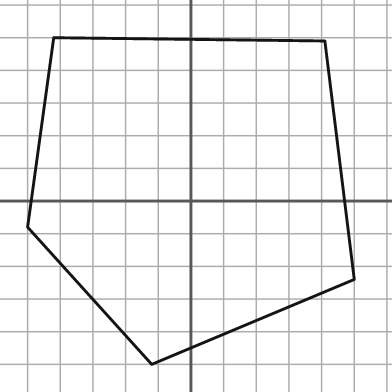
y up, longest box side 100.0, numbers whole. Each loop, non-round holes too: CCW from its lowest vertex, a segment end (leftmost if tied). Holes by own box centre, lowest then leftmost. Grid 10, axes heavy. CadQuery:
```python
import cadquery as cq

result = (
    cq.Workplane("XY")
    .moveTo(-12.0, -50.0)
    .lineTo(50.0, -24.0)
    .lineTo(41.0, 49.0)
    .lineTo(-42.0, 50.0)
    .lineTo(-50.0, -8.0)
    .close()
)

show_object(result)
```